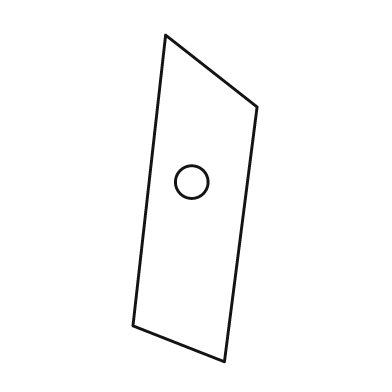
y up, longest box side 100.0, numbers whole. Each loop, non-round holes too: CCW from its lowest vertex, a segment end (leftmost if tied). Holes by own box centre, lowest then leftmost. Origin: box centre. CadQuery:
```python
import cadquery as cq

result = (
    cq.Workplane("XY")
    .moveTo(9.0, -50.0)
    .lineTo(19.0, 28.0)
    .lineTo(-9.0, 50.0)
    .lineTo(-19.0, -39.0)
    .close()
    .moveTo(-1.0, 5.0)
    .circle(5.0)
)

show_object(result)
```